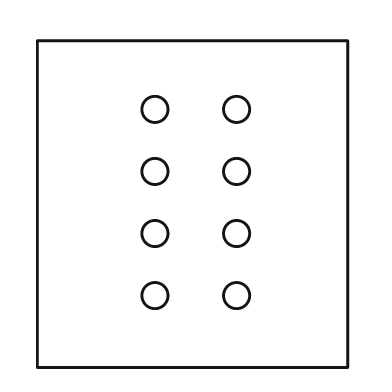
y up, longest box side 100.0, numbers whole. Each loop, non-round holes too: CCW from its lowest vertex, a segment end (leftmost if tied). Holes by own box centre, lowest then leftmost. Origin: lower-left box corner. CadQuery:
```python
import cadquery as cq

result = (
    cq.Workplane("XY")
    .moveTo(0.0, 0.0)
    .lineTo(95.0, 0.0)
    .lineTo(95.0, 100.0)
    .lineTo(0.0, 100.0)
    .close()
    .moveTo(36.0, 22.0)
    .circle(4.0)
    .moveTo(61.0, 22.0)
    .circle(4.0)
    .moveTo(36.0, 41.0)
    .circle(4.0)
    .moveTo(61.0, 41.0)
    .circle(4.0)
    .moveTo(36.0, 60.0)
    .circle(4.0)
    .moveTo(61.0, 60.0)
    .circle(4.0)
    .moveTo(36.0, 79.0)
    .circle(4.0)
    .moveTo(61.0, 79.0)
    .circle(4.0)
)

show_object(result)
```